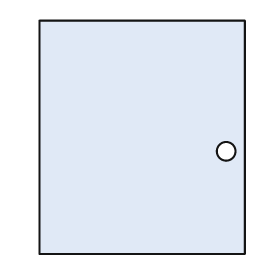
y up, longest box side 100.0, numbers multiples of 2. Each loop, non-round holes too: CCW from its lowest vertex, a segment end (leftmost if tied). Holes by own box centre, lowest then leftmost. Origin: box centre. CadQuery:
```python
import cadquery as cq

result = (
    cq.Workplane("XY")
    .moveTo(-44.0, -50.0)
    .lineTo(44.0, -50.0)
    .lineTo(44.0, 50.0)
    .lineTo(-44.0, 50.0)
    .close()
    .moveTo(36.0, -6.0)
    .circle(4.0)
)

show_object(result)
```